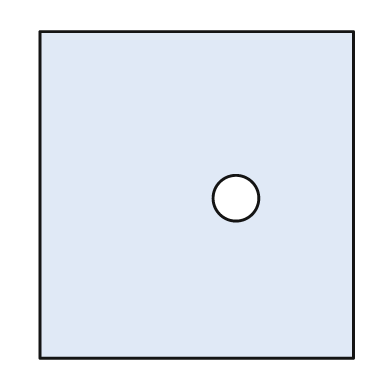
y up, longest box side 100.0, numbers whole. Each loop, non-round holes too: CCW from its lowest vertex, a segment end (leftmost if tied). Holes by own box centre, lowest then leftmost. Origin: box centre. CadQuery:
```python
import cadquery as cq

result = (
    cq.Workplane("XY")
    .moveTo(-48.0, -50.0)
    .lineTo(48.0, -50.0)
    .lineTo(48.0, 50.0)
    .lineTo(-48.0, 50.0)
    .close()
    .moveTo(12.0, -1.0)
    .circle(7.0)
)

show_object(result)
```